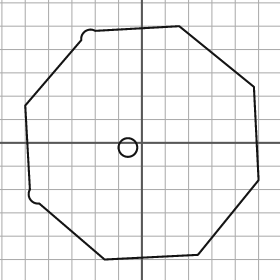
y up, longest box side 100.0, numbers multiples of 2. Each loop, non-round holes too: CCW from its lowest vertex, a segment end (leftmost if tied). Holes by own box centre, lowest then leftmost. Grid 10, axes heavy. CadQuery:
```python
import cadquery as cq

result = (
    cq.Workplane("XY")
    .moveTo(-16.0, -50.0)
    .lineTo(24.0, -48.0)
    .lineTo(50.0, -16.0)
    .lineTo(48.0, 24.0)
    .lineTo(16.0, 50.0)
    .lineTo(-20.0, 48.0)
    .threePointArc((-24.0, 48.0), (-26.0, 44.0))
    .lineTo(-50.0, 16.0)
    .lineTo(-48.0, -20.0)
    .threePointArc((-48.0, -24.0), (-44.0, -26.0))
    .close()
    .moveTo(-6.0, -2.0)
    .circle(4.0)
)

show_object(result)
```